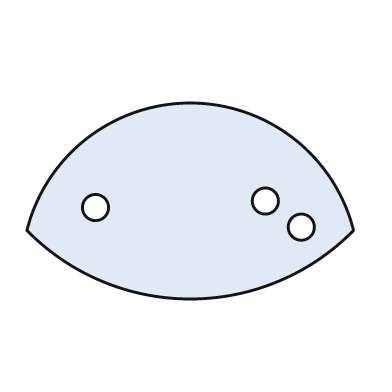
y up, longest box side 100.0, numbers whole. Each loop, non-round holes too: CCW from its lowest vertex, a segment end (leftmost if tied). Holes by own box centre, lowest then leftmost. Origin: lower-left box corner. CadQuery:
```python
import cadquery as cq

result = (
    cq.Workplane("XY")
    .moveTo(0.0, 21.0)
    .threePointArc((50.0, 0.0), (100.0, 21.0))
    .threePointArc((50.0, 60.0), (0.0, 21.0))
    .close()
    .moveTo(84.0, 22.0)
    .circle(4.0)
    .moveTo(21.0, 28.0)
    .circle(4.0)
    .moveTo(73.0, 30.0)
    .circle(4.0)
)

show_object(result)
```